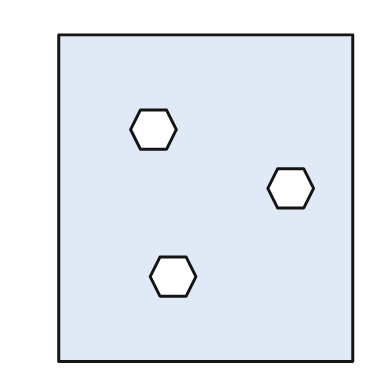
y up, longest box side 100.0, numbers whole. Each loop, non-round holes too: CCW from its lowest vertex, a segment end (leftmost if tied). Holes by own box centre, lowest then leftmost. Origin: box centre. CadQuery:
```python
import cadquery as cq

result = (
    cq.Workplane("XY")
    .moveTo(-45.0, -50.0)
    .lineTo(45.0, -50.0)
    .lineTo(45.0, 50.0)
    .lineTo(-45.0, 50.0)
    .close()
    .moveTo(-14.0, -30.0)
    .lineTo(-6.0, -30.0)
    .lineTo(-3.0, -24.0)
    .lineTo(-6.0, -18.0)
    .lineTo(-14.0, -18.0)
    .lineTo(-17.0, -24.0)
    .close()
    .moveTo(22.0, -3.0)
    .lineTo(30.0, -3.0)
    .lineTo(33.0, 3.0)
    .lineTo(30.0, 9.0)
    .lineTo(22.0, 9.0)
    .lineTo(19.0, 3.0)
    .close()
    .moveTo(-20.0, 15.0)
    .lineTo(-12.0, 15.0)
    .lineTo(-9.0, 21.0)
    .lineTo(-12.0, 27.0)
    .lineTo(-20.0, 27.0)
    .lineTo(-23.0, 21.0)
    .close()
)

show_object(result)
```